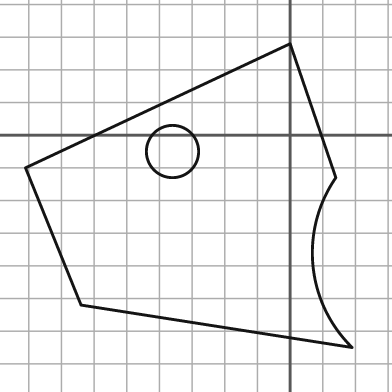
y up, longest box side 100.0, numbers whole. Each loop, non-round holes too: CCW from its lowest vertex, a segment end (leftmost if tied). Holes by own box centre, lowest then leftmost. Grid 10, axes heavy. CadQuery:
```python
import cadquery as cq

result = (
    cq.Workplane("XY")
    .moveTo(19.0, -65.0)
    .threePointArc((7.0, -40.0), (14.0, -13.0))
    .lineTo(0.0, 28.0)
    .lineTo(-81.0, -10.0)
    .lineTo(-64.0, -52.0)
    .close()
    .moveTo(-36.0, -5.0)
    .circle(8.0)
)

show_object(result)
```